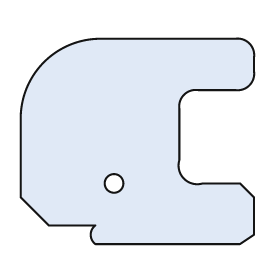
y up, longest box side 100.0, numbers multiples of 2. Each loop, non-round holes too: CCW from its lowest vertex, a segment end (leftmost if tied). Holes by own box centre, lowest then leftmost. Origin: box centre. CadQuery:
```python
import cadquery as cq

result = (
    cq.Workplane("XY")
    .moveTo(-18.0, -44.0)
    .lineTo(44.0, -44.0)
    .lineTo(50.0, -40.0)
    .lineTo(50.0, -24.0)
    .lineTo(44.0, -18.0)
    .lineTo(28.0, -18.0)
    .threePointArc((20.0, -16.0), (18.0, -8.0))
    .lineTo(18.0, 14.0)
    .threePointArc((20.0, 20.0), (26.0, 22.0))
    .lineTo(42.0, 22.0)
    .threePointArc((48.0, 24.0), (50.0, 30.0))
    .lineTo(50.0, 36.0)
    .threePointArc((48.0, 42.0), (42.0, 44.0))
    .lineTo(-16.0, 44.0)
    .threePointArc((-40.0, 34.0), (-50.0, 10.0))
    .lineTo(-50.0, -24.0)
    .lineTo(-38.0, -36.0)
    .lineTo(-18.0, -36.0)
    .threePointArc((-20.0, -40.0), (-18.0, -44.0))
    .close()
    .moveTo(-10.0, -18.0)
    .circle(4.0)
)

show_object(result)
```